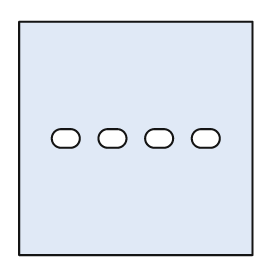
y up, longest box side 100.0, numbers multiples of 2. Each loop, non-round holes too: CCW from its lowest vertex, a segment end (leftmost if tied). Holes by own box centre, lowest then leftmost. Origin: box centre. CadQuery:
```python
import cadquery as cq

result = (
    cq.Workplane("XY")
    .moveTo(-50.0, -50.0)
    .lineTo(50.0, -50.0)
    .lineTo(50.0, 50.0)
    .lineTo(-50.0, 50.0)
    .close()
    .moveTo(-32.0, -4.0)
    .lineTo(-28.0, -4.0)
    .threePointArc((-24.0, 0.0), (-28.0, 4.0))
    .lineTo(-32.0, 4.0)
    .threePointArc((-36.0, 0.0), (-32.0, -4.0))
    .close()
    .moveTo(-12.0, -4.0)
    .lineTo(-8.0, -4.0)
    .threePointArc((-4.0, 0.0), (-8.0, 4.0))
    .lineTo(-12.0, 4.0)
    .threePointArc((-16.0, 0.0), (-12.0, -4.0))
    .close()
    .moveTo(8.0, -4.0)
    .lineTo(12.0, -4.0)
    .threePointArc((16.0, 0.0), (12.0, 4.0))
    .lineTo(8.0, 4.0)
    .threePointArc((4.0, 0.0), (8.0, -4.0))
    .close()
    .moveTo(28.0, -4.0)
    .lineTo(32.0, -4.0)
    .threePointArc((36.0, 0.0), (32.0, 4.0))
    .lineTo(28.0, 4.0)
    .threePointArc((24.0, 0.0), (28.0, -4.0))
    .close()
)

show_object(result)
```